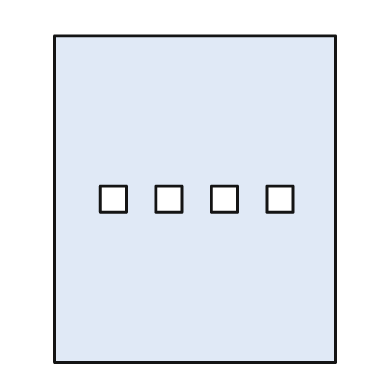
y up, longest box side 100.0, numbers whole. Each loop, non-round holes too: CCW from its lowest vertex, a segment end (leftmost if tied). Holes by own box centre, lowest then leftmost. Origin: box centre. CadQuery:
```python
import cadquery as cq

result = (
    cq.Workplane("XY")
    .moveTo(-43.0, -50.0)
    .lineTo(43.0, -50.0)
    .lineTo(43.0, 50.0)
    .lineTo(-43.0, 50.0)
    .close()
    .moveTo(-29.0, -4.0)
    .lineTo(-21.0, -4.0)
    .lineTo(-21.0, 4.0)
    .lineTo(-29.0, 4.0)
    .close()
    .moveTo(-12.0, -4.0)
    .lineTo(-4.0, -4.0)
    .lineTo(-4.0, 4.0)
    .lineTo(-12.0, 4.0)
    .close()
    .moveTo(5.0, -4.0)
    .lineTo(13.0, -4.0)
    .lineTo(13.0, 4.0)
    .lineTo(5.0, 4.0)
    .close()
    .moveTo(22.0, -4.0)
    .lineTo(30.0, -4.0)
    .lineTo(30.0, 4.0)
    .lineTo(22.0, 4.0)
    .close()
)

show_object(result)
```